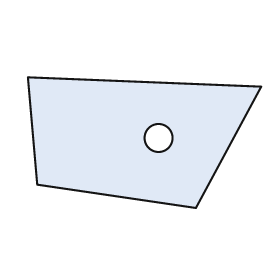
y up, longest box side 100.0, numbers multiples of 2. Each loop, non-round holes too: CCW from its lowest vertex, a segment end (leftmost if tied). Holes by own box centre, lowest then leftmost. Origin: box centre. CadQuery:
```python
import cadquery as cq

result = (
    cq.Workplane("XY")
    .moveTo(22.0, -28.0)
    .lineTo(50.0, 24.0)
    .lineTo(-50.0, 28.0)
    .lineTo(-46.0, -18.0)
    .close()
    .moveTo(6.0, 2.0)
    .circle(6.0)
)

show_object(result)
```